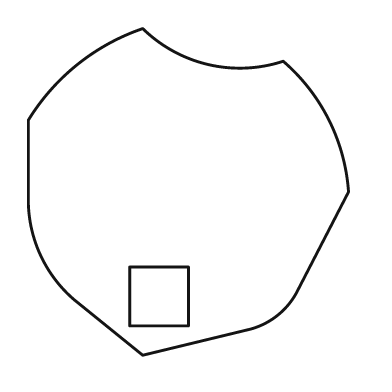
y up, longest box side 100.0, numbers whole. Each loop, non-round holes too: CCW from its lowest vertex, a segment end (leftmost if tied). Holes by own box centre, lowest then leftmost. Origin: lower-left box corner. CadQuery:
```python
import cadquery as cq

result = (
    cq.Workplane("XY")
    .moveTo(35.0, 0.0)
    .lineTo(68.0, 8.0)
    .threePointArc((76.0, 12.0), (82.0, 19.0))
    .lineTo(98.0, 50.0)
    .threePointArc((92.0, 72.0), (78.0, 90.0))
    .threePointArc((55.0, 89.0), (35.0, 100.0))
    .threePointArc((15.0, 89.0), (0.0, 72.0))
    .lineTo(0.0, 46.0)
    .threePointArc((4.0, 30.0), (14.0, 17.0))
    .close()
    .moveTo(31.0, 9.0)
    .lineTo(49.0, 9.0)
    .lineTo(49.0, 27.0)
    .lineTo(31.0, 27.0)
    .close()
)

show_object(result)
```